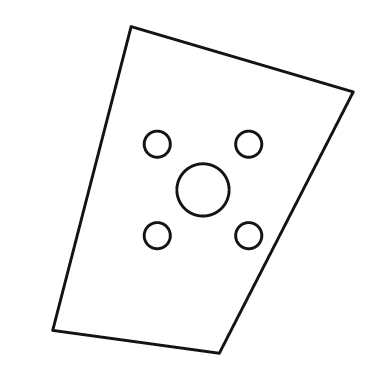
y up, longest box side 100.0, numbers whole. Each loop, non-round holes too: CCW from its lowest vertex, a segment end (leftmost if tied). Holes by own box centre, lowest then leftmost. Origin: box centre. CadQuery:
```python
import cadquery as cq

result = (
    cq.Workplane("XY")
    .moveTo(5.0, -50.0)
    .lineTo(46.0, 30.0)
    .lineTo(-22.0, 50.0)
    .lineTo(-46.0, -43.0)
    .close()
    .moveTo(-14.0, -14.0)
    .circle(4.0)
    .moveTo(14.0, -14.0)
    .circle(4.0)
    .moveTo(0.0, 0.0)
    .circle(8.0)
    .moveTo(-14.0, 14.0)
    .circle(4.0)
    .moveTo(14.0, 14.0)
    .circle(4.0)
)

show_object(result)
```